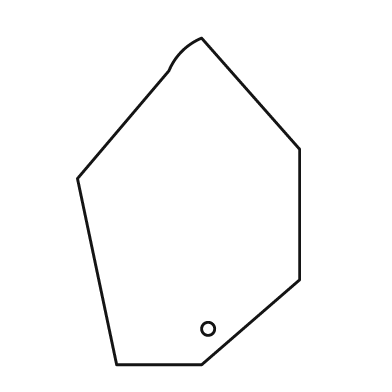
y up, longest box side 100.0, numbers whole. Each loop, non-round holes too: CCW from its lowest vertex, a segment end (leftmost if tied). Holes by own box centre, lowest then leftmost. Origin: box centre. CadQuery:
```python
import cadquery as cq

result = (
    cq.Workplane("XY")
    .moveTo(-22.0, -50.0)
    .lineTo(4.0, -50.0)
    .lineTo(34.0, -24.0)
    .lineTo(34.0, 16.0)
    .lineTo(4.0, 50.0)
    .threePointArc((-2.0, 46.0), (-6.0, 40.0))
    .lineTo(-34.0, 7.0)
    .close()
    .moveTo(6.0, -39.0)
    .circle(2.0)
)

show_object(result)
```